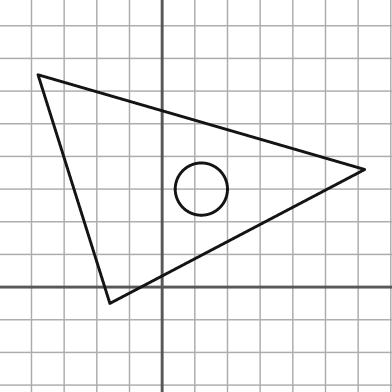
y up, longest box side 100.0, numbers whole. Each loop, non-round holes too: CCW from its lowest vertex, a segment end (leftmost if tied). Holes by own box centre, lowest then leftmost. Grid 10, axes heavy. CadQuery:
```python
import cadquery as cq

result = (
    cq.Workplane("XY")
    .moveTo(-16.0, -5.0)
    .lineTo(62.0, 36.0)
    .lineTo(-38.0, 65.0)
    .close()
    .moveTo(12.0, 30.0)
    .circle(8.0)
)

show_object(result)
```